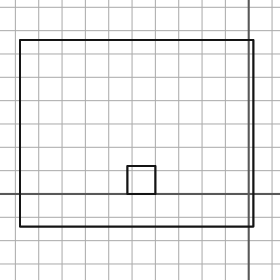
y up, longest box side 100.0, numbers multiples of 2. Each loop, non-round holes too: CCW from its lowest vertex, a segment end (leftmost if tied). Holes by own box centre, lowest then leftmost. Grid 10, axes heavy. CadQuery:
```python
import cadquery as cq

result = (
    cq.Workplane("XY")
    .moveTo(-98.0, -14.0)
    .lineTo(2.0, -14.0)
    .lineTo(2.0, 66.0)
    .lineTo(-98.0, 66.0)
    .close()
    .moveTo(-52.0, 0.0)
    .lineTo(-40.0, 0.0)
    .lineTo(-40.0, 12.0)
    .lineTo(-52.0, 12.0)
    .close()
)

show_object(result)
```